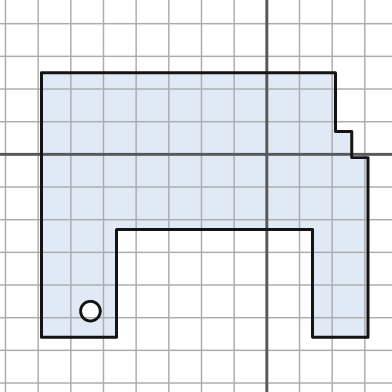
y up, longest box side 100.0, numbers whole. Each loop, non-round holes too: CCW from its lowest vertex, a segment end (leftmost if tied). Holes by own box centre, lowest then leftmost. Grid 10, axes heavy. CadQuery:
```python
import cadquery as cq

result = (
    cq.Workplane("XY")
    .moveTo(-69.0, -56.0)
    .lineTo(-46.0, -56.0)
    .lineTo(-46.0, -23.0)
    .lineTo(14.0, -23.0)
    .lineTo(14.0, -56.0)
    .lineTo(31.0, -56.0)
    .lineTo(31.0, -1.0)
    .lineTo(26.0, -1.0)
    .lineTo(26.0, 7.0)
    .lineTo(21.0, 7.0)
    .lineTo(21.0, 25.0)
    .lineTo(-69.0, 25.0)
    .close()
    .moveTo(-54.0, -48.0)
    .circle(3.0)
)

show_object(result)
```